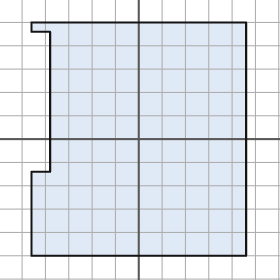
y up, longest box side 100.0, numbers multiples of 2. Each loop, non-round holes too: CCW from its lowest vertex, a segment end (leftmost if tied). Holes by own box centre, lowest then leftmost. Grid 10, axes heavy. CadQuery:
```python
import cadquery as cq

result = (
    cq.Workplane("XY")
    .moveTo(-46.0, -50.0)
    .lineTo(46.0, -50.0)
    .lineTo(46.0, 50.0)
    .lineTo(-46.0, 50.0)
    .lineTo(-46.0, 46.0)
    .lineTo(-38.0, 46.0)
    .lineTo(-38.0, -14.0)
    .lineTo(-46.0, -14.0)
    .close()
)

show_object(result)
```